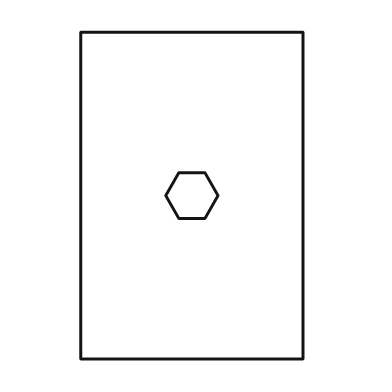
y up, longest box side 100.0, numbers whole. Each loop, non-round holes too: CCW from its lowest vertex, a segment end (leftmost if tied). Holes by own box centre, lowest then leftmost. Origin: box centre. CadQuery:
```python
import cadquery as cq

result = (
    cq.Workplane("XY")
    .moveTo(-34.0, -50.0)
    .lineTo(34.0, -50.0)
    .lineTo(34.0, 50.0)
    .lineTo(-34.0, 50.0)
    .close()
    .moveTo(-4.0, -7.0)
    .lineTo(4.0, -7.0)
    .lineTo(8.0, 0.0)
    .lineTo(4.0, 7.0)
    .lineTo(-4.0, 7.0)
    .lineTo(-8.0, 0.0)
    .close()
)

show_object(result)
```